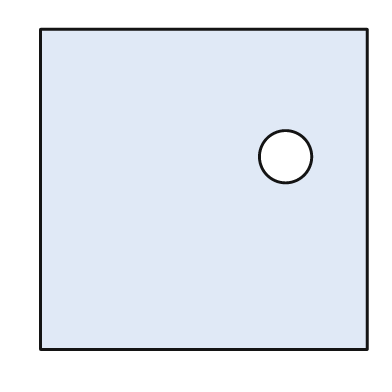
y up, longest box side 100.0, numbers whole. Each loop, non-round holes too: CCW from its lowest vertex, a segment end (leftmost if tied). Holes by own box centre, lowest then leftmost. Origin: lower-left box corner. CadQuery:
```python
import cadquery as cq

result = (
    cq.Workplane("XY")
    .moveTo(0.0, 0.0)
    .lineTo(100.0, 0.0)
    .lineTo(100.0, 98.0)
    .lineTo(0.0, 98.0)
    .close()
    .moveTo(75.0, 59.0)
    .circle(8.0)
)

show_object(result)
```